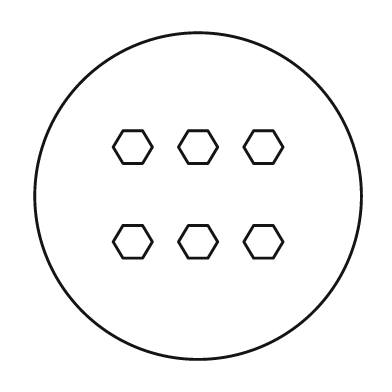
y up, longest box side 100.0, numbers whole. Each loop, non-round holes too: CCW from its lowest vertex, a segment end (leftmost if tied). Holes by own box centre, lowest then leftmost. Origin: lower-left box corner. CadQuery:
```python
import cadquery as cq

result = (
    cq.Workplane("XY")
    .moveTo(50.0, 50.0)
    .circle(50.0)
    .moveTo(27.0, 31.0)
    .lineTo(33.0, 31.0)
    .lineTo(36.0, 36.0)
    .lineTo(33.0, 41.0)
    .lineTo(27.0, 41.0)
    .lineTo(24.0, 36.0)
    .close()
    .moveTo(47.0, 31.0)
    .lineTo(53.0, 31.0)
    .lineTo(56.0, 36.0)
    .lineTo(53.0, 41.0)
    .lineTo(47.0, 41.0)
    .lineTo(44.0, 36.0)
    .close()
    .moveTo(67.0, 31.0)
    .lineTo(73.0, 31.0)
    .lineTo(76.0, 36.0)
    .lineTo(73.0, 41.0)
    .lineTo(67.0, 41.0)
    .lineTo(64.0, 36.0)
    .close()
    .moveTo(27.0, 60.0)
    .lineTo(33.0, 60.0)
    .lineTo(36.0, 65.0)
    .lineTo(33.0, 70.0)
    .lineTo(27.0, 70.0)
    .lineTo(24.0, 65.0)
    .close()
    .moveTo(47.0, 60.0)
    .lineTo(53.0, 60.0)
    .lineTo(56.0, 65.0)
    .lineTo(53.0, 70.0)
    .lineTo(47.0, 70.0)
    .lineTo(44.0, 65.0)
    .close()
    .moveTo(67.0, 60.0)
    .lineTo(73.0, 60.0)
    .lineTo(76.0, 65.0)
    .lineTo(73.0, 70.0)
    .lineTo(67.0, 70.0)
    .lineTo(64.0, 65.0)
    .close()
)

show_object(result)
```